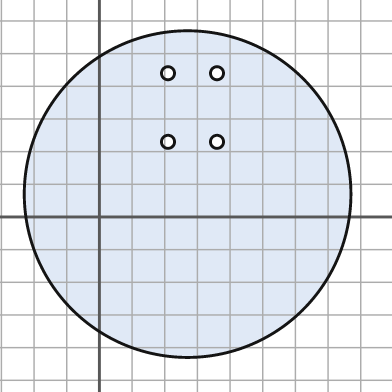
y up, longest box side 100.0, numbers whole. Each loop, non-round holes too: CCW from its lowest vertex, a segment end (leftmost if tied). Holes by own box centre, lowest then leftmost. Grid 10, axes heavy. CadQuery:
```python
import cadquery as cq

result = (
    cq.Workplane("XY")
    .moveTo(27.0, 7.0)
    .circle(50.0)
    .moveTo(21.0, 23.0)
    .circle(2.0)
    .moveTo(36.0, 23.0)
    .circle(2.0)
    .moveTo(21.0, 44.0)
    .circle(2.0)
    .moveTo(36.0, 44.0)
    .circle(2.0)
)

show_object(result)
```